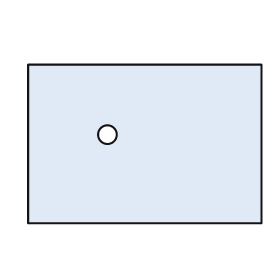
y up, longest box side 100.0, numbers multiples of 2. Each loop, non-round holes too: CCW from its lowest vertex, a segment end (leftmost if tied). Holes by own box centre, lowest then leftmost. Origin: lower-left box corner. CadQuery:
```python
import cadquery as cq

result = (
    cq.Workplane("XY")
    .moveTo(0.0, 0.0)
    .lineTo(100.0, 0.0)
    .lineTo(100.0, 68.0)
    .lineTo(0.0, 68.0)
    .close()
    .moveTo(34.0, 38.0)
    .circle(4.0)
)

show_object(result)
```